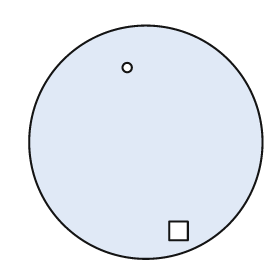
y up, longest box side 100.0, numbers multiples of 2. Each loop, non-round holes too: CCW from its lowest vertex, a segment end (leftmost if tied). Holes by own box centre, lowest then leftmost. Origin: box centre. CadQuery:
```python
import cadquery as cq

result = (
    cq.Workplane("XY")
    .moveTo(0.0, 0.0)
    .circle(50.0)
    .moveTo(10.0, -42.0)
    .lineTo(18.0, -42.0)
    .lineTo(18.0, -34.0)
    .lineTo(10.0, -34.0)
    .close()
    .moveTo(-8.0, 32.0)
    .circle(2.0)
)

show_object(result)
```